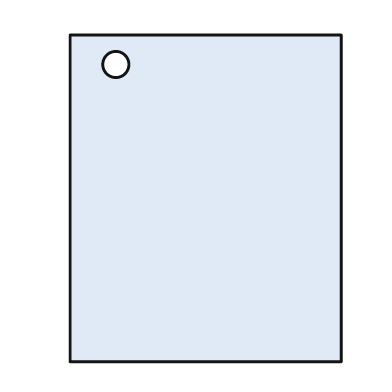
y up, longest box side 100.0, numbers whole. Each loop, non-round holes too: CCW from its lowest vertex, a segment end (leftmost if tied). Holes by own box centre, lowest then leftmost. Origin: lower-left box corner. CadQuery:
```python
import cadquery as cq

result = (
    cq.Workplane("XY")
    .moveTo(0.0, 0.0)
    .lineTo(83.0, 0.0)
    .lineTo(83.0, 100.0)
    .lineTo(0.0, 100.0)
    .close()
    .moveTo(14.0, 91.0)
    .circle(4.0)
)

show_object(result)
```